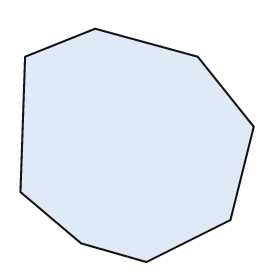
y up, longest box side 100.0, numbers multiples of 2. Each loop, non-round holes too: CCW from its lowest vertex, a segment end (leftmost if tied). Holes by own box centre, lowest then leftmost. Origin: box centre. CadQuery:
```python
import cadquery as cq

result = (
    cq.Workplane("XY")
    .moveTo(4.0, -50.0)
    .lineTo(40.0, -32.0)
    .lineTo(50.0, 8.0)
    .lineTo(26.0, 38.0)
    .lineTo(-18.0, 50.0)
    .lineTo(-48.0, 38.0)
    .lineTo(-50.0, -20.0)
    .lineTo(-24.0, -42.0)
    .close()
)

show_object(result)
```